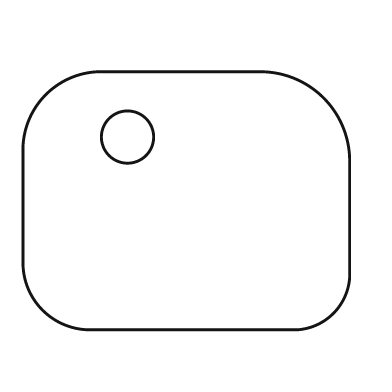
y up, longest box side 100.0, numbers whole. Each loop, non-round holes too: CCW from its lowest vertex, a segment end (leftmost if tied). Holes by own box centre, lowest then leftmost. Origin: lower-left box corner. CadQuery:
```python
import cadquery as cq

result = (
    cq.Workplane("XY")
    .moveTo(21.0, 0.0)
    .lineTo(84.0, 0.0)
    .threePointArc((95.0, 5.0), (100.0, 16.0))
    .lineTo(100.0, 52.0)
    .threePointArc((92.0, 71.0), (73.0, 79.0))
    .lineTo(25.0, 79.0)
    .threePointArc((7.0, 72.0), (0.0, 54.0))
    .lineTo(0.0, 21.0)
    .threePointArc((6.0, 6.0), (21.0, 0.0))
    .close()
    .moveTo(32.0, 59.0)
    .circle(8.0)
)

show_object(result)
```